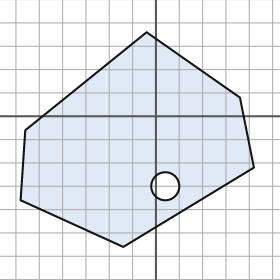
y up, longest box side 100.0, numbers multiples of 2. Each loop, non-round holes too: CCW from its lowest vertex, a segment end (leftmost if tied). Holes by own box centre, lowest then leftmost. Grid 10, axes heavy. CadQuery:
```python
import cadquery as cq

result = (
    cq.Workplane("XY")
    .moveTo(-14.0, -56.0)
    .lineTo(42.0, -22.0)
    .lineTo(36.0, 8.0)
    .lineTo(-4.0, 36.0)
    .lineTo(-56.0, -6.0)
    .lineTo(-58.0, -36.0)
    .close()
    .moveTo(4.0, -30.0)
    .circle(6.0)
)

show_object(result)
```